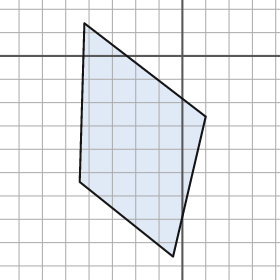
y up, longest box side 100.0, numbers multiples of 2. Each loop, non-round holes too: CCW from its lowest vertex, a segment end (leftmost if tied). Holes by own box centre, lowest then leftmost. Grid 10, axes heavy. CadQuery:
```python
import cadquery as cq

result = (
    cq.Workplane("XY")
    .moveTo(-4.0, -86.0)
    .lineTo(10.0, -26.0)
    .lineTo(-42.0, 14.0)
    .lineTo(-44.0, -54.0)
    .close()
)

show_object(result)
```